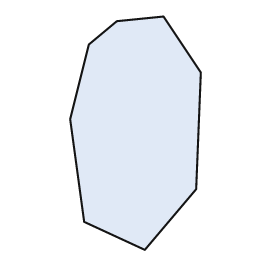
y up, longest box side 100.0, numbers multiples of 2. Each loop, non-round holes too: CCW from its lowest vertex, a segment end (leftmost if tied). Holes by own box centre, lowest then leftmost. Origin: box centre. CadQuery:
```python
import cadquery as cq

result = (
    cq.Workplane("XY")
    .moveTo(4.0, -50.0)
    .lineTo(26.0, -24.0)
    .lineTo(28.0, 26.0)
    .lineTo(12.0, 50.0)
    .lineTo(-8.0, 48.0)
    .lineTo(-20.0, 38.0)
    .lineTo(-28.0, 6.0)
    .lineTo(-22.0, -38.0)
    .close()
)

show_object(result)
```